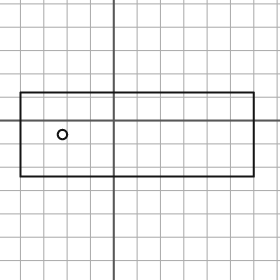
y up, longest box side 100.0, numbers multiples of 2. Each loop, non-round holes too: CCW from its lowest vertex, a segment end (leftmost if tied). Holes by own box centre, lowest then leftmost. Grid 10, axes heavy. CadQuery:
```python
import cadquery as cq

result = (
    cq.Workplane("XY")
    .moveTo(-40.0, -24.0)
    .lineTo(60.0, -24.0)
    .lineTo(60.0, 12.0)
    .lineTo(-40.0, 12.0)
    .close()
    .moveTo(-22.0, -6.0)
    .circle(2.0)
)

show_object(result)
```